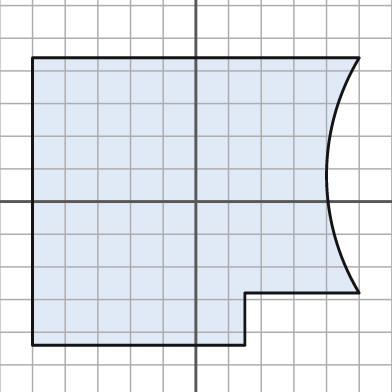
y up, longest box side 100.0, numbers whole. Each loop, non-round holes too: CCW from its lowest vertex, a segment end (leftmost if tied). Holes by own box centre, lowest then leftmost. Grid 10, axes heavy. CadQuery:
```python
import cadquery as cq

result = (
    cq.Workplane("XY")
    .moveTo(-50.0, -44.0)
    .lineTo(15.0, -44.0)
    .lineTo(15.0, -28.0)
    .lineTo(50.0, -28.0)
    .threePointArc((40.0, 8.0), (50.0, 44.0))
    .lineTo(-50.0, 44.0)
    .close()
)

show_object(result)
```